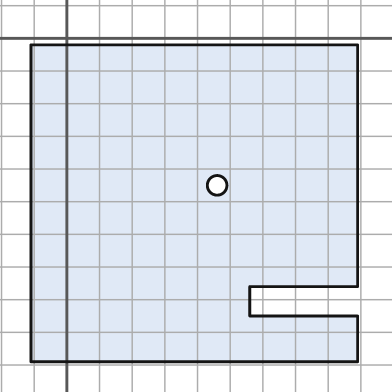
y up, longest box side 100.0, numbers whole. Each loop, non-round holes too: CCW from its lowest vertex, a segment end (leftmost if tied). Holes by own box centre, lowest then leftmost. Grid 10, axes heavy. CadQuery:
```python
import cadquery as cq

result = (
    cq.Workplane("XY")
    .moveTo(-11.0, -99.0)
    .lineTo(89.0, -99.0)
    .lineTo(89.0, -85.0)
    .lineTo(56.0, -85.0)
    .lineTo(56.0, -76.0)
    .lineTo(89.0, -76.0)
    .lineTo(89.0, -2.0)
    .lineTo(-11.0, -2.0)
    .close()
    .moveTo(46.0, -45.0)
    .circle(3.0)
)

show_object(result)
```